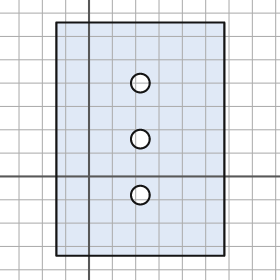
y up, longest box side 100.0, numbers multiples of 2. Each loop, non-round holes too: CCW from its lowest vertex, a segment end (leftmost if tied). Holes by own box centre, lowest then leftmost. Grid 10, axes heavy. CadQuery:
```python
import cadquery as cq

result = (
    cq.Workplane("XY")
    .moveTo(-14.0, -34.0)
    .lineTo(58.0, -34.0)
    .lineTo(58.0, 66.0)
    .lineTo(-14.0, 66.0)
    .close()
    .moveTo(22.0, -8.0)
    .circle(4.0)
    .moveTo(22.0, 16.0)
    .circle(4.0)
    .moveTo(22.0, 40.0)
    .circle(4.0)
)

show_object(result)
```